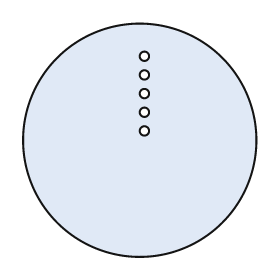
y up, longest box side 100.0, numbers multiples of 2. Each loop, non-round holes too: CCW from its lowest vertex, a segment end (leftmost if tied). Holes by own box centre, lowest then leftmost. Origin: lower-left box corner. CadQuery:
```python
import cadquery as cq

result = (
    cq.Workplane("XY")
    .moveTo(50.0, 50.0)
    .circle(50.0)
    .moveTo(52.0, 54.0)
    .circle(2.0)
    .moveTo(52.0, 62.0)
    .circle(2.0)
    .moveTo(52.0, 70.0)
    .circle(2.0)
    .moveTo(52.0, 78.0)
    .circle(2.0)
    .moveTo(52.0, 86.0)
    .circle(2.0)
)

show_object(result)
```